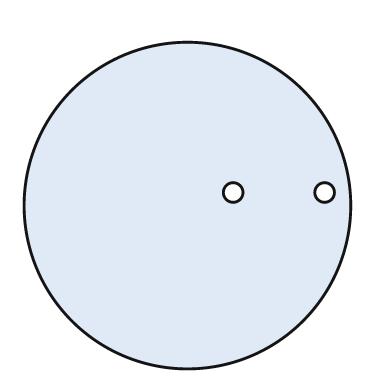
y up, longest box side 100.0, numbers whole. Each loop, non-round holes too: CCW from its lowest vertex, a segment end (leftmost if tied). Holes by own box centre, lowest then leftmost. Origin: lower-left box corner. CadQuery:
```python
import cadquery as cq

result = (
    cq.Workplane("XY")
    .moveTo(50.0, 50.0)
    .circle(50.0)
    .moveTo(64.0, 54.0)
    .circle(3.0)
    .moveTo(92.0, 54.0)
    .circle(3.0)
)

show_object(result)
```